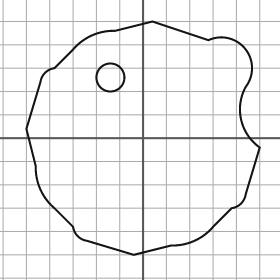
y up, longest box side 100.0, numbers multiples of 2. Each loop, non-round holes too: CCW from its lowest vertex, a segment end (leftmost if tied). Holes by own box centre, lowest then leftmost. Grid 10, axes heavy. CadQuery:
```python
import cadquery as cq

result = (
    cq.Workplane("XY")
    .moveTo(-4.0, -50.0)
    .lineTo(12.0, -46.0)
    .threePointArc((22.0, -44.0), (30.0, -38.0))
    .lineTo(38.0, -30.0)
    .threePointArc((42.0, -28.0), (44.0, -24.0))
    .lineTo(50.0, -4.0)
    .threePointArc((42.0, 8.0), (44.0, 22.0))
    .threePointArc((44.0, 38.0), (28.0, 42.0))
    .lineTo(4.0, 50.0)
    .lineTo(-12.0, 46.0)
    .threePointArc((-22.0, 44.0), (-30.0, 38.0))
    .lineTo(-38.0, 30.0)
    .threePointArc((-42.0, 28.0), (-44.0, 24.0))
    .lineTo(-50.0, 4.0)
    .lineTo(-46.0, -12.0)
    .threePointArc((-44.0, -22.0), (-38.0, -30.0))
    .lineTo(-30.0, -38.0)
    .threePointArc((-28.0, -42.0), (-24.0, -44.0))
    .close()
    .moveTo(-14.0, 26.0)
    .circle(6.0)
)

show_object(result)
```